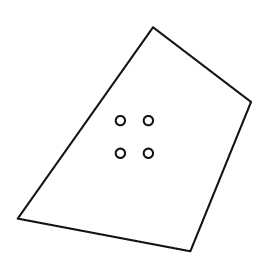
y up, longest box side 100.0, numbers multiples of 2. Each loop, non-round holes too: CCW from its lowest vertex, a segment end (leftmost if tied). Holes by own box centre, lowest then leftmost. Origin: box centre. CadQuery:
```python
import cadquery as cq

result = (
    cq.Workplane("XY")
    .moveTo(24.0, -48.0)
    .lineTo(50.0, 16.0)
    .lineTo(8.0, 48.0)
    .lineTo(-50.0, -34.0)
    .close()
    .moveTo(-6.0, -6.0)
    .circle(2.0)
    .moveTo(6.0, -6.0)
    .circle(2.0)
    .moveTo(-6.0, 8.0)
    .circle(2.0)
    .moveTo(6.0, 8.0)
    .circle(2.0)
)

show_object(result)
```